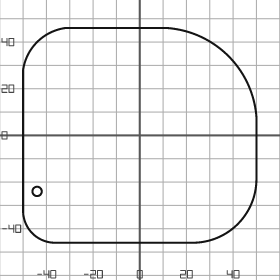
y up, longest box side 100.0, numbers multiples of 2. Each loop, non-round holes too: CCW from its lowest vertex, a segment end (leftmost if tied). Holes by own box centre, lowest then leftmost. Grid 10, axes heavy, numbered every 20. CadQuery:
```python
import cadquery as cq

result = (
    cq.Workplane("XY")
    .moveTo(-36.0, -46.0)
    .lineTo(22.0, -46.0)
    .threePointArc((42.0, -38.0), (50.0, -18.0))
    .lineTo(50.0, 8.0)
    .threePointArc((38.0, 34.0), (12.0, 46.0))
    .lineTo(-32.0, 46.0)
    .threePointArc((-44.0, 40.0), (-50.0, 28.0))
    .lineTo(-50.0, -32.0)
    .threePointArc((-46.0, -42.0), (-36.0, -46.0))
    .close()
    .moveTo(-44.0, -24.0)
    .circle(2.0)
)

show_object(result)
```